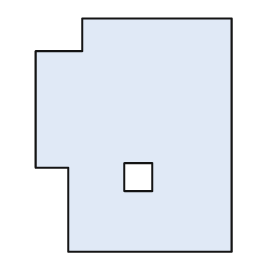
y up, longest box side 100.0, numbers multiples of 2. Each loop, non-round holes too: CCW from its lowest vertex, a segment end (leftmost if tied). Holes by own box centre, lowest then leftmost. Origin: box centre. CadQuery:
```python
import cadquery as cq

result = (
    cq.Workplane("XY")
    .moveTo(-28.0, -50.0)
    .lineTo(42.0, -50.0)
    .lineTo(42.0, 50.0)
    .lineTo(-22.0, 50.0)
    .lineTo(-22.0, 36.0)
    .lineTo(-42.0, 36.0)
    .lineTo(-42.0, -14.0)
    .lineTo(-28.0, -14.0)
    .close()
    .moveTo(-4.0, -24.0)
    .lineTo(8.0, -24.0)
    .lineTo(8.0, -12.0)
    .lineTo(-4.0, -12.0)
    .close()
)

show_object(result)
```